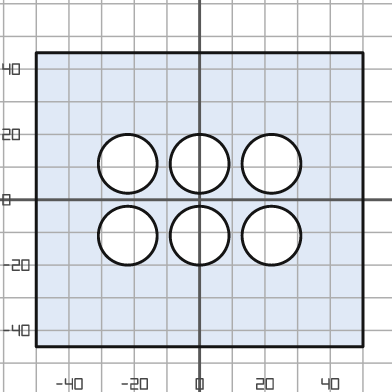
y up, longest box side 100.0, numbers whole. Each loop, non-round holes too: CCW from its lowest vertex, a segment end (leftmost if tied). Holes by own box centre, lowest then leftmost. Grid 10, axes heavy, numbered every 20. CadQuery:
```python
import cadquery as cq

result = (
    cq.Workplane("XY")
    .moveTo(-50.0, -45.0)
    .lineTo(50.0, -45.0)
    .lineTo(50.0, 45.0)
    .lineTo(-50.0, 45.0)
    .close()
    .moveTo(-22.0, -11.0)
    .circle(9.0)
    .moveTo(0.0, -11.0)
    .circle(9.0)
    .moveTo(22.0, -11.0)
    .circle(9.0)
    .moveTo(-22.0, 11.0)
    .circle(9.0)
    .moveTo(0.0, 11.0)
    .circle(9.0)
    .moveTo(22.0, 11.0)
    .circle(9.0)
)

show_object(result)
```